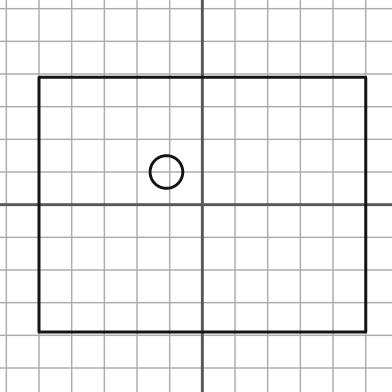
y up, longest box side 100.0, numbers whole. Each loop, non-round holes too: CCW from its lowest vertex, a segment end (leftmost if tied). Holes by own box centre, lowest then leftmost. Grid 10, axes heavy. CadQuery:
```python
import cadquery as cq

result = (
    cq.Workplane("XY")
    .moveTo(-50.0, -39.0)
    .lineTo(50.0, -39.0)
    .lineTo(50.0, 39.0)
    .lineTo(-50.0, 39.0)
    .close()
    .moveTo(-11.0, 10.0)
    .circle(5.0)
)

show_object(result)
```